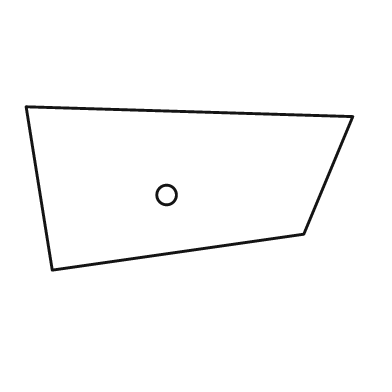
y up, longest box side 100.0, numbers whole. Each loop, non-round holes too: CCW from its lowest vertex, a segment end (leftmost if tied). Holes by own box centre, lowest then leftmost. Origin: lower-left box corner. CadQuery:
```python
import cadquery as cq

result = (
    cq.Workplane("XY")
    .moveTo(8.0, 0.0)
    .lineTo(85.0, 11.0)
    .lineTo(100.0, 47.0)
    .lineTo(0.0, 50.0)
    .close()
    .moveTo(43.0, 23.0)
    .circle(3.0)
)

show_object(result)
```